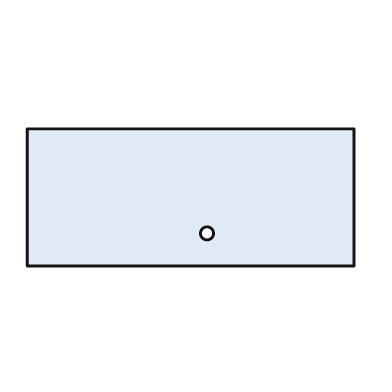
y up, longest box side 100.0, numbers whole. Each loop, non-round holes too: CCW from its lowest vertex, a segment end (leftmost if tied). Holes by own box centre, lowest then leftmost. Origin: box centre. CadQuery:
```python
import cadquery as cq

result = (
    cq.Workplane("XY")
    .moveTo(-50.0, -21.0)
    .lineTo(50.0, -21.0)
    .lineTo(50.0, 21.0)
    .lineTo(-50.0, 21.0)
    .close()
    .moveTo(5.0, -11.0)
    .circle(2.0)
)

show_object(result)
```